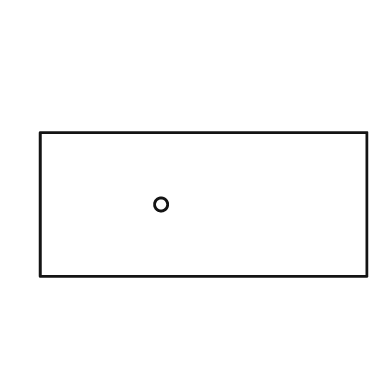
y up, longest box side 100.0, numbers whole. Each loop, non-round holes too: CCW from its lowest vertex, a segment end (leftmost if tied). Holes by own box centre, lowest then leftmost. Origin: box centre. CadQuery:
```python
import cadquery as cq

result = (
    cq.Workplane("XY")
    .moveTo(-50.0, -22.0)
    .lineTo(50.0, -22.0)
    .lineTo(50.0, 22.0)
    .lineTo(-50.0, 22.0)
    .close()
    .moveTo(-13.0, 0.0)
    .circle(2.0)
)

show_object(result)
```